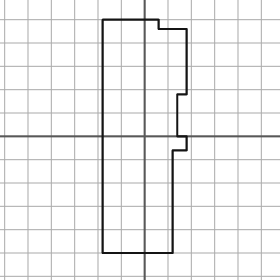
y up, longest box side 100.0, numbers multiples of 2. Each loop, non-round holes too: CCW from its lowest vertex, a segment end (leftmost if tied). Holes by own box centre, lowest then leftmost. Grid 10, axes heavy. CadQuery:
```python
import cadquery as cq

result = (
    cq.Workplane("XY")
    .moveTo(-18.0, -50.0)
    .lineTo(12.0, -50.0)
    .lineTo(12.0, -6.0)
    .lineTo(18.0, -6.0)
    .lineTo(18.0, 0.0)
    .lineTo(14.0, 0.0)
    .lineTo(14.0, 18.0)
    .lineTo(18.0, 18.0)
    .lineTo(18.0, 46.0)
    .lineTo(6.0, 46.0)
    .lineTo(6.0, 50.0)
    .lineTo(-18.0, 50.0)
    .close()
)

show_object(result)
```